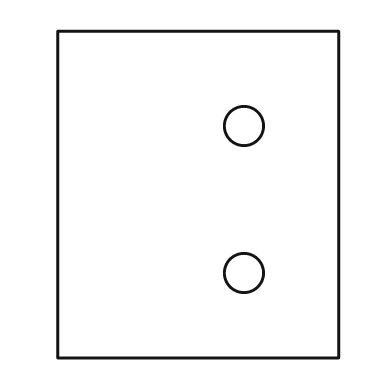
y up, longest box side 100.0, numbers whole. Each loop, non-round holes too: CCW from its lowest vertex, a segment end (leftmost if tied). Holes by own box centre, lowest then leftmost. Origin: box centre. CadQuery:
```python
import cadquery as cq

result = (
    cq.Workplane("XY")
    .moveTo(-43.0, -50.0)
    .lineTo(43.0, -50.0)
    .lineTo(43.0, 50.0)
    .lineTo(-43.0, 50.0)
    .close()
    .moveTo(14.0, -24.0)
    .circle(6.0)
    .moveTo(14.0, 21.0)
    .circle(6.0)
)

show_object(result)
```